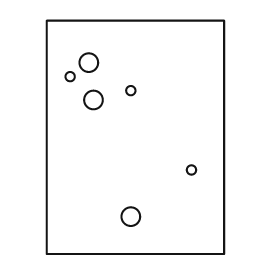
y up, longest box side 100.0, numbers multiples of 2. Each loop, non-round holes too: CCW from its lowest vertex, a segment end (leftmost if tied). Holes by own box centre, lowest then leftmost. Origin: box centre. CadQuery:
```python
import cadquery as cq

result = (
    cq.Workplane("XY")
    .moveTo(-38.0, -50.0)
    .lineTo(38.0, -50.0)
    .lineTo(38.0, 50.0)
    .lineTo(-38.0, 50.0)
    .close()
    .moveTo(-2.0, -34.0)
    .circle(4.0)
    .moveTo(24.0, -14.0)
    .circle(2.0)
    .moveTo(-18.0, 16.0)
    .circle(4.0)
    .moveTo(-2.0, 20.0)
    .circle(2.0)
    .moveTo(-28.0, 26.0)
    .circle(2.0)
    .moveTo(-20.0, 32.0)
    .circle(4.0)
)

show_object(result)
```